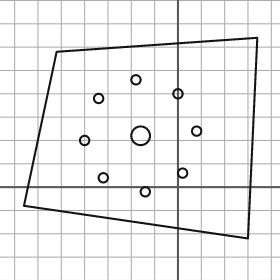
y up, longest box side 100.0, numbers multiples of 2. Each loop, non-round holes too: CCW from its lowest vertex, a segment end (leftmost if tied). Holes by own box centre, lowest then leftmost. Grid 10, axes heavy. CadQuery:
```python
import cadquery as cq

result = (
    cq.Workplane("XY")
    .moveTo(30.0, -22.0)
    .lineTo(34.0, 64.0)
    .lineTo(-52.0, 58.0)
    .lineTo(-66.0, -8.0)
    .close()
    .moveTo(-14.0, -2.0)
    .circle(2.0)
    .moveTo(-32.0, 4.0)
    .circle(2.0)
    .moveTo(2.0, 6.0)
    .circle(2.0)
    .moveTo(-40.0, 20.0)
    .circle(2.0)
    .moveTo(-16.0, 22.0)
    .circle(4.0)
    .moveTo(8.0, 24.0)
    .circle(2.0)
    .moveTo(-34.0, 38.0)
    .circle(2.0)
    .moveTo(0.0, 40.0)
    .circle(2.0)
    .moveTo(-18.0, 46.0)
    .circle(2.0)
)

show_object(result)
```